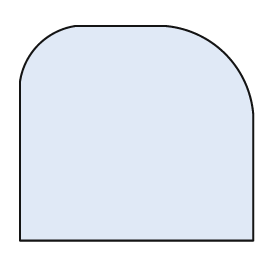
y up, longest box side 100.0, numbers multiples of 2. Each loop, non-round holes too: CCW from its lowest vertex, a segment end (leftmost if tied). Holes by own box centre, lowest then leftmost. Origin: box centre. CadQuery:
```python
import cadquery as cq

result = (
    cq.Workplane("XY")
    .moveTo(-50.0, -46.0)
    .lineTo(50.0, -46.0)
    .lineTo(50.0, 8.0)
    .threePointArc((38.0, 34.0), (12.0, 46.0))
    .lineTo(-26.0, 46.0)
    .threePointArc((-42.0, 38.0), (-50.0, 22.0))
    .close()
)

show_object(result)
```